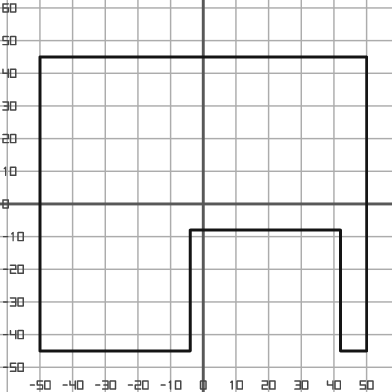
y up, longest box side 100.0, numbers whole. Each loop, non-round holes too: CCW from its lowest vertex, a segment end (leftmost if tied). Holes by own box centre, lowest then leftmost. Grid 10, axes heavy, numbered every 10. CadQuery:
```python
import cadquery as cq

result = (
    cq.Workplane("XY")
    .moveTo(-50.0, -45.0)
    .lineTo(-4.0, -45.0)
    .lineTo(-4.0, -8.0)
    .lineTo(42.0, -8.0)
    .lineTo(42.0, -45.0)
    .lineTo(50.0, -45.0)
    .lineTo(50.0, 45.0)
    .lineTo(-50.0, 45.0)
    .close()
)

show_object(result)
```